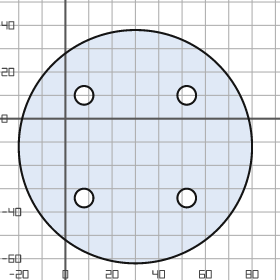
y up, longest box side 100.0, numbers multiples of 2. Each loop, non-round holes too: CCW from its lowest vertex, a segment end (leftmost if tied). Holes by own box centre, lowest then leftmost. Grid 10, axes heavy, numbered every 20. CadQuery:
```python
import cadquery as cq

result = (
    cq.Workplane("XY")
    .moveTo(30.0, -12.0)
    .circle(50.0)
    .moveTo(8.0, -34.0)
    .circle(4.0)
    .moveTo(52.0, -34.0)
    .circle(4.0)
    .moveTo(8.0, 10.0)
    .circle(4.0)
    .moveTo(52.0, 10.0)
    .circle(4.0)
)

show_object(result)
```